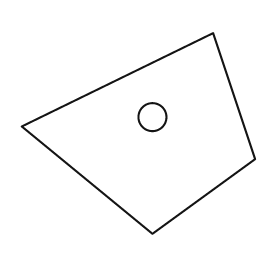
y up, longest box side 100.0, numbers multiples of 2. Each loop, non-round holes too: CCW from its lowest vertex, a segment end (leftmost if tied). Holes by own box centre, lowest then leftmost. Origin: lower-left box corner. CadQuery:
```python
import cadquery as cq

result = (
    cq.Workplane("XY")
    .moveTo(56.0, 0.0)
    .lineTo(100.0, 32.0)
    .lineTo(82.0, 86.0)
    .lineTo(0.0, 46.0)
    .close()
    .moveTo(56.0, 50.0)
    .circle(6.0)
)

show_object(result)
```